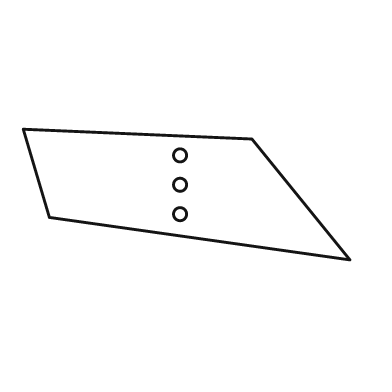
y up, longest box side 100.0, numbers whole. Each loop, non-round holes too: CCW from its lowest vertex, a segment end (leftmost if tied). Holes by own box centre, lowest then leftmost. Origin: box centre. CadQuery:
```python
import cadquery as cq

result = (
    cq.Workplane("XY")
    .moveTo(50.0, -20.0)
    .lineTo(20.0, 17.0)
    .lineTo(-50.0, 20.0)
    .lineTo(-42.0, -7.0)
    .close()
    .moveTo(-2.0, -6.0)
    .circle(2.0)
    .moveTo(-2.0, 3.0)
    .circle(2.0)
    .moveTo(-2.0, 12.0)
    .circle(2.0)
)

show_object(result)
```